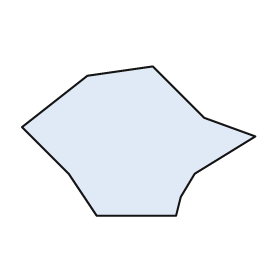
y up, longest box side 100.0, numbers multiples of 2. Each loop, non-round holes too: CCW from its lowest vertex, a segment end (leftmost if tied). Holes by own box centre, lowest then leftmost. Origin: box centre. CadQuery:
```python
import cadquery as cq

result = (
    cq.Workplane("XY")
    .moveTo(-18.0, -32.0)
    .lineTo(16.0, -32.0)
    .lineTo(18.0, -24.0)
    .lineTo(24.0, -14.0)
    .lineTo(50.0, 2.0)
    .lineTo(28.0, 10.0)
    .lineTo(6.0, 32.0)
    .lineTo(-22.0, 28.0)
    .lineTo(-50.0, 6.0)
    .lineTo(-30.0, -14.0)
    .close()
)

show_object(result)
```